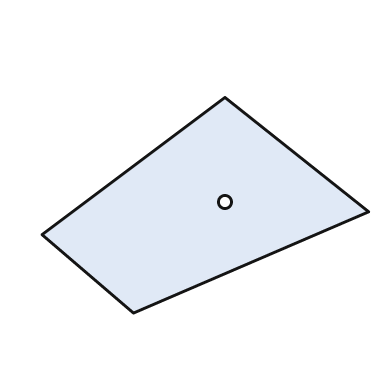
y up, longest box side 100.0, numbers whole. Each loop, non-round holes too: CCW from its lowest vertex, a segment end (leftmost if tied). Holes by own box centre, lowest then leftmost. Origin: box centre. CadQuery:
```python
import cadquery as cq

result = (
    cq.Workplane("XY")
    .moveTo(-22.0, -33.0)
    .lineTo(50.0, -2.0)
    .lineTo(6.0, 33.0)
    .lineTo(-50.0, -9.0)
    .close()
    .moveTo(6.0, 1.0)
    .circle(2.0)
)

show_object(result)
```